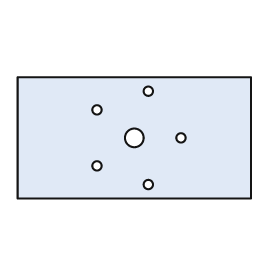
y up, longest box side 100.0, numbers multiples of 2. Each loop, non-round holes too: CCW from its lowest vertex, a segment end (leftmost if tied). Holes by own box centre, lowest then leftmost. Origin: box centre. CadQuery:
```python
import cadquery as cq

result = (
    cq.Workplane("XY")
    .moveTo(-50.0, -26.0)
    .lineTo(50.0, -26.0)
    .lineTo(50.0, 26.0)
    .lineTo(-50.0, 26.0)
    .close()
    .moveTo(6.0, -20.0)
    .circle(2.0)
    .moveTo(-16.0, -12.0)
    .circle(2.0)
    .moveTo(0.0, 0.0)
    .circle(4.0)
    .moveTo(20.0, 0.0)
    .circle(2.0)
    .moveTo(-16.0, 12.0)
    .circle(2.0)
    .moveTo(6.0, 20.0)
    .circle(2.0)
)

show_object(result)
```